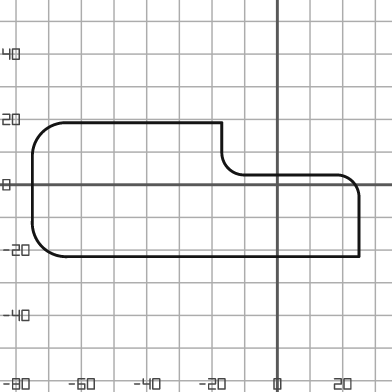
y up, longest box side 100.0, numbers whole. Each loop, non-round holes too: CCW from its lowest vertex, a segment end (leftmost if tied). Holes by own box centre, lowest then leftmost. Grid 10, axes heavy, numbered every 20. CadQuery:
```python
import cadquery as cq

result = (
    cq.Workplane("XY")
    .moveTo(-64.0, -22.0)
    .lineTo(25.0, -22.0)
    .lineTo(25.0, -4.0)
    .threePointArc((23.0, 1.0), (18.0, 3.0))
    .lineTo(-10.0, 3.0)
    .threePointArc((-15.0, 5.0), (-17.0, 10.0))
    .lineTo(-17.0, 19.0)
    .lineTo(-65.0, 19.0)
    .threePointArc((-72.0, 16.0), (-75.0, 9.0))
    .lineTo(-75.0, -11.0)
    .threePointArc((-72.0, -19.0), (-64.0, -22.0))
    .close()
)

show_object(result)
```